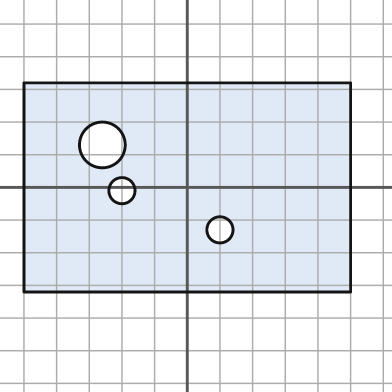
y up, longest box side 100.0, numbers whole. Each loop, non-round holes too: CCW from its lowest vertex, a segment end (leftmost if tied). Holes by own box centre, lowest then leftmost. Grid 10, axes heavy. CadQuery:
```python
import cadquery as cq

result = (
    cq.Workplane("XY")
    .moveTo(-50.0, -32.0)
    .lineTo(50.0, -32.0)
    .lineTo(50.0, 32.0)
    .lineTo(-50.0, 32.0)
    .close()
    .moveTo(10.0, -13.0)
    .circle(4.0)
    .moveTo(-20.0, -1.0)
    .circle(4.0)
    .moveTo(-26.0, 13.0)
    .circle(7.0)
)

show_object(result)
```